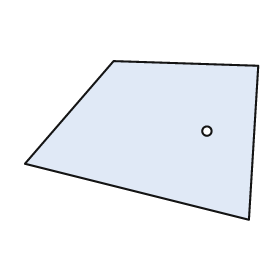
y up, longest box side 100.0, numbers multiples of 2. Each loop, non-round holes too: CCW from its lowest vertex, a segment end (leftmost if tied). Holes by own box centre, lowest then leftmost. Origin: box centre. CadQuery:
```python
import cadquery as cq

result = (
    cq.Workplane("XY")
    .moveTo(46.0, -34.0)
    .lineTo(50.0, 32.0)
    .lineTo(-12.0, 34.0)
    .lineTo(-50.0, -10.0)
    .close()
    .moveTo(28.0, 4.0)
    .circle(2.0)
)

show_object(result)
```